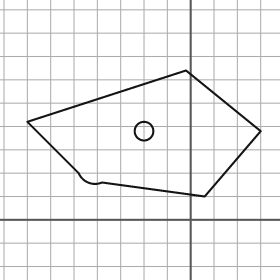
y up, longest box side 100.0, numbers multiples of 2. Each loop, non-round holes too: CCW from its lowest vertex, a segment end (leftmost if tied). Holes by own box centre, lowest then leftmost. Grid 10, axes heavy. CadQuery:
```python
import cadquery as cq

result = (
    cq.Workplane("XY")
    .moveTo(6.0, 10.0)
    .lineTo(30.0, 38.0)
    .lineTo(-2.0, 64.0)
    .lineTo(-70.0, 42.0)
    .lineTo(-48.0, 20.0)
    .threePointArc((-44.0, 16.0), (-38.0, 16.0))
    .close()
    .moveTo(-20.0, 38.0)
    .circle(4.0)
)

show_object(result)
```